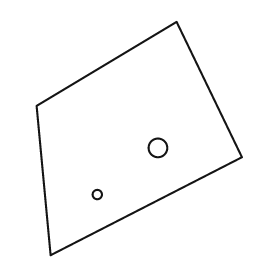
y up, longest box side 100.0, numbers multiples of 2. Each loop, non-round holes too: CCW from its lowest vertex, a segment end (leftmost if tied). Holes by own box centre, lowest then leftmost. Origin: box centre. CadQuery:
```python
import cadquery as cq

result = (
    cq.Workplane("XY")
    .moveTo(-38.0, -50.0)
    .lineTo(44.0, -8.0)
    .lineTo(16.0, 50.0)
    .lineTo(-44.0, 14.0)
    .close()
    .moveTo(-18.0, -24.0)
    .circle(2.0)
    .moveTo(8.0, -4.0)
    .circle(4.0)
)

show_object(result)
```